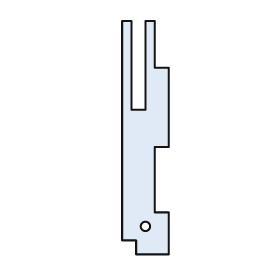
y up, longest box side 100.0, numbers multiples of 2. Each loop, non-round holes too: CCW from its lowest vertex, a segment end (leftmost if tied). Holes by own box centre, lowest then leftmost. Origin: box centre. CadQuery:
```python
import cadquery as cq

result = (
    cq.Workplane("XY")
    .moveTo(-4.0, -50.0)
    .lineTo(10.0, -50.0)
    .lineTo(10.0, -32.0)
    .lineTo(4.0, -32.0)
    .lineTo(4.0, -4.0)
    .lineTo(10.0, -4.0)
    .lineTo(10.0, 30.0)
    .lineTo(4.0, 30.0)
    .lineTo(4.0, 50.0)
    .lineTo(0.0, 50.0)
    .lineTo(0.0, 12.0)
    .lineTo(-6.0, 12.0)
    .lineTo(-6.0, 50.0)
    .lineTo(-10.0, 50.0)
    .lineTo(-10.0, -44.0)
    .lineTo(-4.0, -44.0)
    .close()
    .moveTo(0.0, -38.0)
    .circle(2.0)
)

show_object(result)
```